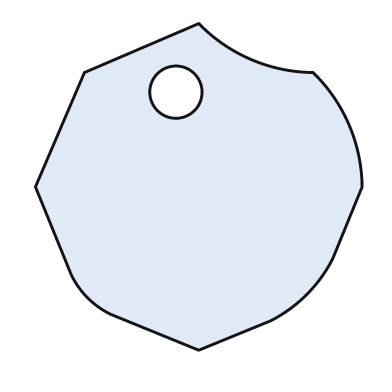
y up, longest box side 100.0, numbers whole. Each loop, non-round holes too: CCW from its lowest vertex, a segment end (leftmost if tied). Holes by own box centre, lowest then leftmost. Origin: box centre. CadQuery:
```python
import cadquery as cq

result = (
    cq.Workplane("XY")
    .moveTo(0.0, -50.0)
    .lineTo(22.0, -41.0)
    .threePointArc((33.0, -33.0), (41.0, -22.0))
    .lineTo(50.0, 0.0)
    .threePointArc((46.0, 19.0), (35.0, 35.0))
    .threePointArc((16.0, 39.0), (0.0, 50.0))
    .lineTo(-35.0, 35.0)
    .lineTo(-50.0, 0.0)
    .lineTo(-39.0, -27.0)
    .threePointArc((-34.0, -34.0), (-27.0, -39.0))
    .close()
    .moveTo(-7.0, 29.0)
    .circle(8.0)
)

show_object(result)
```